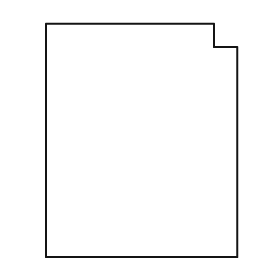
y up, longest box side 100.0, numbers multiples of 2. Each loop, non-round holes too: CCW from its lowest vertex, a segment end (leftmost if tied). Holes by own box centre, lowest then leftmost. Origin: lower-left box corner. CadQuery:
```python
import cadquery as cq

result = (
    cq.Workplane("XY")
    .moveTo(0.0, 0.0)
    .lineTo(82.0, 0.0)
    .lineTo(82.0, 90.0)
    .lineTo(72.0, 90.0)
    .lineTo(72.0, 100.0)
    .lineTo(0.0, 100.0)
    .close()
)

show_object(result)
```